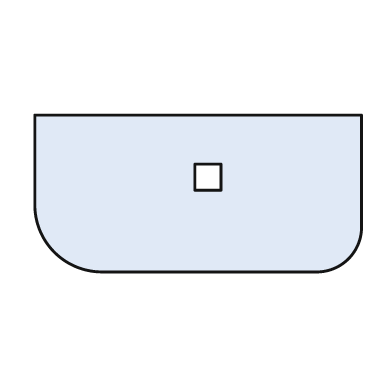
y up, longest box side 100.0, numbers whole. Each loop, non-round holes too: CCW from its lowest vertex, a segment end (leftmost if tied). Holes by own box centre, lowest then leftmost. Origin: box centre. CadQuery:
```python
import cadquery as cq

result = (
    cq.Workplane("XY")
    .moveTo(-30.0, -24.0)
    .lineTo(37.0, -24.0)
    .threePointArc((46.0, -20.0), (50.0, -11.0))
    .lineTo(50.0, 24.0)
    .lineTo(-50.0, 24.0)
    .lineTo(-50.0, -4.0)
    .threePointArc((-44.0, -18.0), (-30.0, -24.0))
    .close()
    .moveTo(-1.0, 1.0)
    .lineTo(7.0, 1.0)
    .lineTo(7.0, 9.0)
    .lineTo(-1.0, 9.0)
    .close()
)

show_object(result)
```